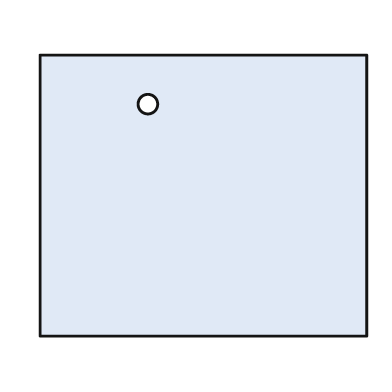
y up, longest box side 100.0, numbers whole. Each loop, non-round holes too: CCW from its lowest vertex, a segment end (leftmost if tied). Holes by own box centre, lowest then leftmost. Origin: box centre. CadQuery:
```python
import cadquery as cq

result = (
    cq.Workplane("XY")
    .moveTo(-50.0, -43.0)
    .lineTo(50.0, -43.0)
    .lineTo(50.0, 43.0)
    .lineTo(-50.0, 43.0)
    .close()
    .moveTo(-17.0, 28.0)
    .circle(3.0)
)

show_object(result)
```